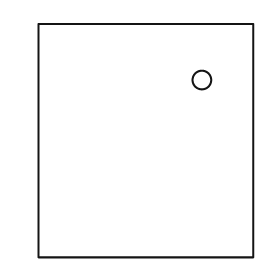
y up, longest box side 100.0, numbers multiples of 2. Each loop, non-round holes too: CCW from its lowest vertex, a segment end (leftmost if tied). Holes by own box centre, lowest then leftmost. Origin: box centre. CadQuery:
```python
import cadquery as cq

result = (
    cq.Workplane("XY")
    .moveTo(-46.0, -50.0)
    .lineTo(46.0, -50.0)
    .lineTo(46.0, 50.0)
    .lineTo(-46.0, 50.0)
    .close()
    .moveTo(24.0, 26.0)
    .circle(4.0)
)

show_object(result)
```